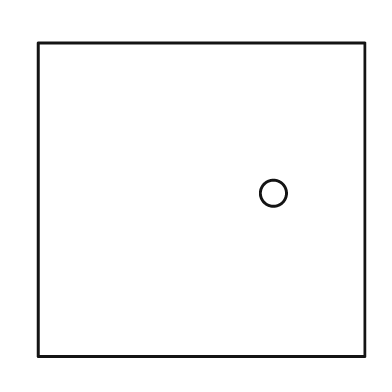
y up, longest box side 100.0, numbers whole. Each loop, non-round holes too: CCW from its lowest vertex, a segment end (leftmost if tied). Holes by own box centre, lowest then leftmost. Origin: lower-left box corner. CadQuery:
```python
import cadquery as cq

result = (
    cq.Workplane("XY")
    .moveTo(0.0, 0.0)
    .lineTo(100.0, 0.0)
    .lineTo(100.0, 96.0)
    .lineTo(0.0, 96.0)
    .close()
    .moveTo(72.0, 50.0)
    .circle(4.0)
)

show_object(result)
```